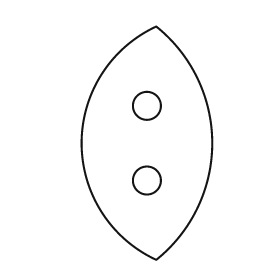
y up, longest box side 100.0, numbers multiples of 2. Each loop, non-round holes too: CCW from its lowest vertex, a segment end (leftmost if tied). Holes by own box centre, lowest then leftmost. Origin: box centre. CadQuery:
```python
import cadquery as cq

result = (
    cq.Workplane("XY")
    .moveTo(4.0, -50.0)
    .threePointArc((28.0, 0.0), (4.0, 50.0))
    .threePointArc((-28.0, 0.0), (4.0, -50.0))
    .close()
    .moveTo(0.0, -16.0)
    .circle(6.0)
    .moveTo(0.0, 16.0)
    .circle(6.0)
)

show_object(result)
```